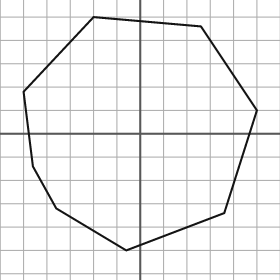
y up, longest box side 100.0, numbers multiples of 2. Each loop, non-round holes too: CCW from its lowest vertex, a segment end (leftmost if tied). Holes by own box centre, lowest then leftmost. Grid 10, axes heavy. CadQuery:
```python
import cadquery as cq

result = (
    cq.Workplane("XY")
    .moveTo(-6.0, -50.0)
    .lineTo(36.0, -34.0)
    .lineTo(50.0, 10.0)
    .lineTo(26.0, 46.0)
    .lineTo(-20.0, 50.0)
    .lineTo(-50.0, 18.0)
    .lineTo(-46.0, -14.0)
    .lineTo(-36.0, -32.0)
    .close()
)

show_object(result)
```